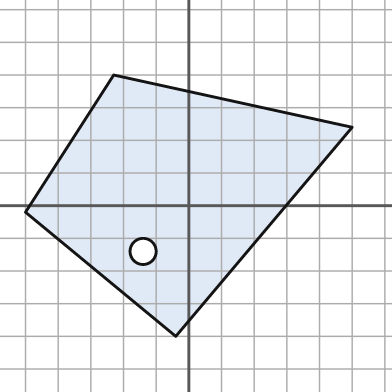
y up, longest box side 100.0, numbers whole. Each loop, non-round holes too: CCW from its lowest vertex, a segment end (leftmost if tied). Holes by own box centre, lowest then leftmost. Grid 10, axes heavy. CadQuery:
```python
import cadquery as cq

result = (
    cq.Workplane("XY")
    .moveTo(-4.0, -40.0)
    .lineTo(50.0, 24.0)
    .lineTo(-23.0, 40.0)
    .lineTo(-50.0, -2.0)
    .close()
    .moveTo(-14.0, -14.0)
    .circle(4.0)
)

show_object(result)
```